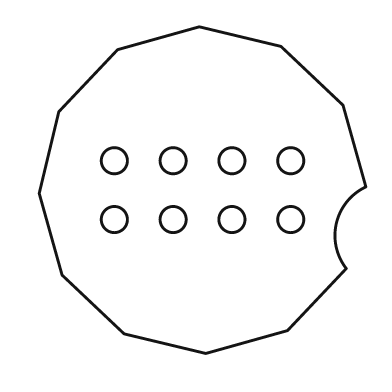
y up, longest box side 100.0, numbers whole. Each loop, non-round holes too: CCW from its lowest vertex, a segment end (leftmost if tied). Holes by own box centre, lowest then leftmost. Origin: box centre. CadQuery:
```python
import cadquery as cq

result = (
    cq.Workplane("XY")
    .moveTo(1.0, -50.0)
    .lineTo(26.0, -43.0)
    .lineTo(44.0, -24.0)
    .threePointArc((41.0, -10.0), (50.0, 1.0))
    .lineTo(43.0, 26.0)
    .lineTo(24.0, 44.0)
    .lineTo(-1.0, 50.0)
    .lineTo(-26.0, 43.0)
    .lineTo(-44.0, 24.0)
    .lineTo(-50.0, -1.0)
    .lineTo(-43.0, -26.0)
    .lineTo(-24.0, -44.0)
    .close()
    .moveTo(-27.0, -9.0)
    .circle(4.0)
    .moveTo(-9.0, -9.0)
    .circle(4.0)
    .moveTo(9.0, -9.0)
    .circle(4.0)
    .moveTo(27.0, -9.0)
    .circle(4.0)
    .moveTo(-27.0, 9.0)
    .circle(4.0)
    .moveTo(-9.0, 9.0)
    .circle(4.0)
    .moveTo(9.0, 9.0)
    .circle(4.0)
    .moveTo(27.0, 9.0)
    .circle(4.0)
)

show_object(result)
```